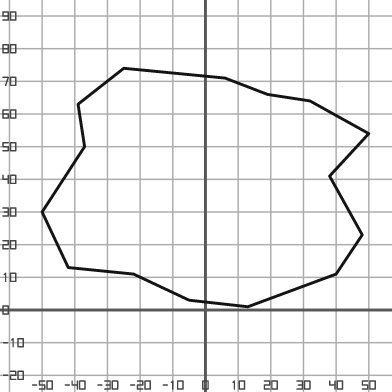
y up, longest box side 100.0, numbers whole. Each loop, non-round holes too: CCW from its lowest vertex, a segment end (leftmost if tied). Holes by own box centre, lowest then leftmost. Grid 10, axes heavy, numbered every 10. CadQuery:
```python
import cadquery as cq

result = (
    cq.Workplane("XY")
    .moveTo(13.0, 1.0)
    .lineTo(40.0, 11.0)
    .lineTo(48.0, 23.0)
    .lineTo(38.0, 41.0)
    .lineTo(50.0, 54.0)
    .lineTo(32.0, 64.0)
    .lineTo(19.0, 66.0)
    .lineTo(6.0, 71.0)
    .lineTo(-25.0, 74.0)
    .lineTo(-39.0, 63.0)
    .lineTo(-37.0, 50.0)
    .lineTo(-50.0, 30.0)
    .lineTo(-42.0, 13.0)
    .lineTo(-22.0, 11.0)
    .lineTo(-5.0, 3.0)
    .close()
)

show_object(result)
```